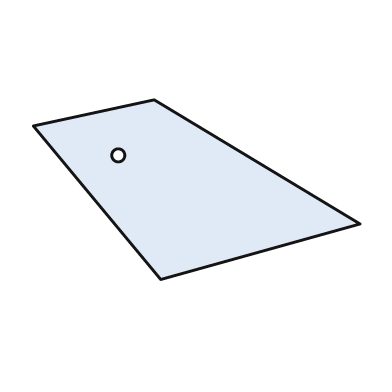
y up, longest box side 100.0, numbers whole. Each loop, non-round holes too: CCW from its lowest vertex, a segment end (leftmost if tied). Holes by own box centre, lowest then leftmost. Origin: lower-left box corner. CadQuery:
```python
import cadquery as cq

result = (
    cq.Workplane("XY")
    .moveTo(39.0, 0.0)
    .lineTo(100.0, 17.0)
    .lineTo(37.0, 55.0)
    .lineTo(0.0, 47.0)
    .close()
    .moveTo(26.0, 38.0)
    .circle(2.0)
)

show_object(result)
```